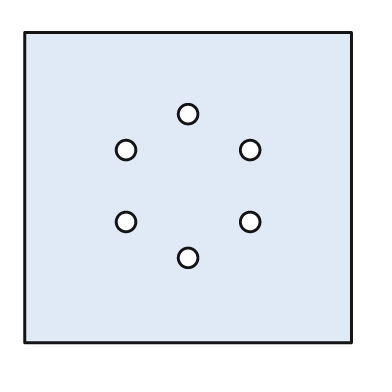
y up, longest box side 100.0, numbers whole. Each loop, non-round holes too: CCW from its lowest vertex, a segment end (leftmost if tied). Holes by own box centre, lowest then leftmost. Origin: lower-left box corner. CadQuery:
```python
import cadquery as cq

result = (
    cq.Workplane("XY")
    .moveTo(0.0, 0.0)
    .lineTo(100.0, 0.0)
    .lineTo(100.0, 95.0)
    .lineTo(0.0, 95.0)
    .close()
    .moveTo(50.0, 26.0)
    .circle(3.0)
    .moveTo(31.0, 37.0)
    .circle(3.0)
    .moveTo(69.0, 37.0)
    .circle(3.0)
    .moveTo(31.0, 59.0)
    .circle(3.0)
    .moveTo(69.0, 59.0)
    .circle(3.0)
    .moveTo(50.0, 70.0)
    .circle(3.0)
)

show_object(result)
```